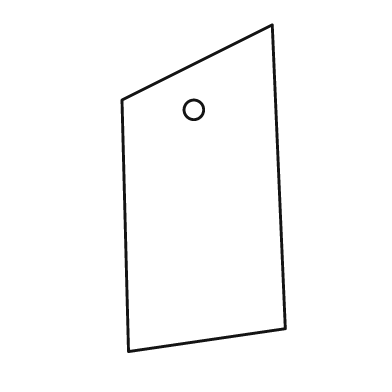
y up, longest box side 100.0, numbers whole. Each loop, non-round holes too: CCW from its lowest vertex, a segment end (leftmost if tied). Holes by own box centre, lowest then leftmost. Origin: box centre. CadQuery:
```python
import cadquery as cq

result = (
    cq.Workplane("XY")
    .moveTo(-23.0, -50.0)
    .lineTo(25.0, -43.0)
    .lineTo(21.0, 50.0)
    .lineTo(-25.0, 27.0)
    .close()
    .moveTo(-3.0, 24.0)
    .circle(3.0)
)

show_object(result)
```